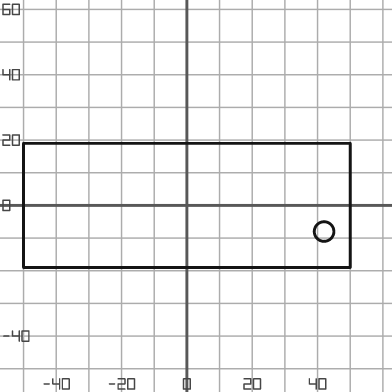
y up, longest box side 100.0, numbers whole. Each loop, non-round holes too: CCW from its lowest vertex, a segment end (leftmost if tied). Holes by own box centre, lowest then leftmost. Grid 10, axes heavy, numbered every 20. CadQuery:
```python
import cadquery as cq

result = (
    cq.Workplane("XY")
    .moveTo(-50.0, -19.0)
    .lineTo(50.0, -19.0)
    .lineTo(50.0, 19.0)
    .lineTo(-50.0, 19.0)
    .close()
    .moveTo(42.0, -8.0)
    .circle(3.0)
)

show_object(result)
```